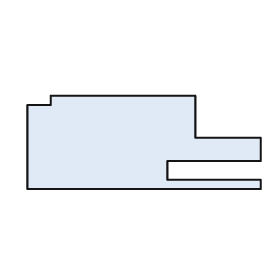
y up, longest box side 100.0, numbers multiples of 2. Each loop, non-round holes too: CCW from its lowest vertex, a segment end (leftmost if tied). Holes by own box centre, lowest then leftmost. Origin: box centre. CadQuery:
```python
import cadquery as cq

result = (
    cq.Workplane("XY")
    .moveTo(-50.0, -20.0)
    .lineTo(50.0, -20.0)
    .lineTo(50.0, -16.0)
    .lineTo(10.0, -16.0)
    .lineTo(10.0, -8.0)
    .lineTo(50.0, -8.0)
    .lineTo(50.0, 2.0)
    .lineTo(22.0, 2.0)
    .lineTo(22.0, 20.0)
    .lineTo(-40.0, 20.0)
    .lineTo(-40.0, 16.0)
    .lineTo(-50.0, 16.0)
    .close()
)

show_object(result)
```